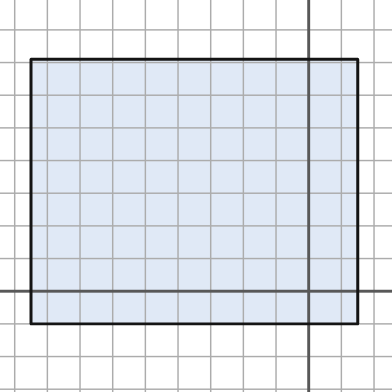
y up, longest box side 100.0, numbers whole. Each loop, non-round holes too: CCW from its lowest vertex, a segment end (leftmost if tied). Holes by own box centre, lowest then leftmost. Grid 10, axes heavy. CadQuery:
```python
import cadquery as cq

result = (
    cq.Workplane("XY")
    .moveTo(-85.0, -10.0)
    .lineTo(15.0, -10.0)
    .lineTo(15.0, 71.0)
    .lineTo(-85.0, 71.0)
    .close()
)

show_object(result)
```